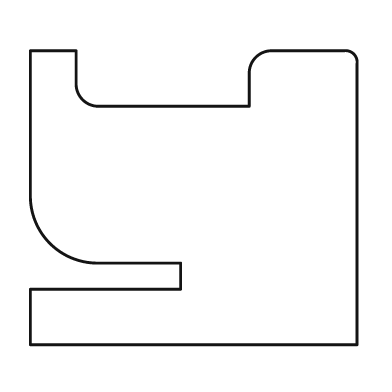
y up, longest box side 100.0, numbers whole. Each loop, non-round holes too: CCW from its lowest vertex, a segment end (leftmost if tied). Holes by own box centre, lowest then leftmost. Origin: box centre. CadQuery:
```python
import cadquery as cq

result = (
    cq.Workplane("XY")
    .moveTo(-50.0, -45.0)
    .lineTo(50.0, -45.0)
    .lineTo(50.0, 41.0)
    .threePointArc((49.0, 44.0), (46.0, 45.0))
    .lineTo(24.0, 45.0)
    .threePointArc((19.0, 43.0), (17.0, 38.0))
    .lineTo(17.0, 28.0)
    .lineTo(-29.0, 28.0)
    .threePointArc((-34.0, 30.0), (-36.0, 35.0))
    .lineTo(-36.0, 45.0)
    .lineTo(-50.0, 45.0)
    .lineTo(-50.0, 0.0)
    .threePointArc((-44.0, -14.0), (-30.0, -20.0))
    .lineTo(-4.0, -20.0)
    .lineTo(-4.0, -28.0)
    .lineTo(-50.0, -28.0)
    .close()
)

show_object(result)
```